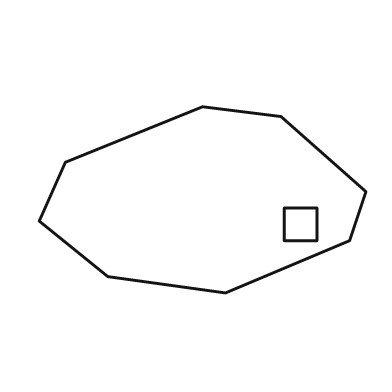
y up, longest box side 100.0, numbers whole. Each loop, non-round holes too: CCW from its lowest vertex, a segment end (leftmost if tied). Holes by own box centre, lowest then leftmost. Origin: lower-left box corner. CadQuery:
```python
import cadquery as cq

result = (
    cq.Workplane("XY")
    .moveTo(57.0, 0.0)
    .lineTo(95.0, 16.0)
    .lineTo(100.0, 31.0)
    .lineTo(74.0, 54.0)
    .lineTo(50.0, 57.0)
    .lineTo(8.0, 40.0)
    .lineTo(0.0, 22.0)
    .lineTo(21.0, 5.0)
    .close()
    .moveTo(75.0, 16.0)
    .lineTo(85.0, 16.0)
    .lineTo(85.0, 26.0)
    .lineTo(75.0, 26.0)
    .close()
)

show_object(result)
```